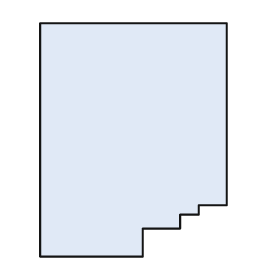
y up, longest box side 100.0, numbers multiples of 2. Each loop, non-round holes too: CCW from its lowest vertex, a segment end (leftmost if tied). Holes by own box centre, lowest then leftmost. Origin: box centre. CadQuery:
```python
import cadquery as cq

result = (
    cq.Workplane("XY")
    .moveTo(-40.0, -50.0)
    .lineTo(4.0, -50.0)
    .lineTo(4.0, -38.0)
    .lineTo(20.0, -38.0)
    .lineTo(20.0, -32.0)
    .lineTo(28.0, -32.0)
    .lineTo(28.0, -28.0)
    .lineTo(40.0, -28.0)
    .lineTo(40.0, 50.0)
    .lineTo(-40.0, 50.0)
    .close()
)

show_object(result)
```